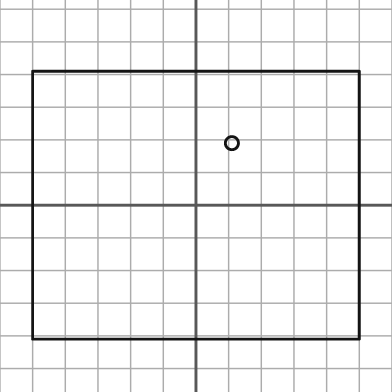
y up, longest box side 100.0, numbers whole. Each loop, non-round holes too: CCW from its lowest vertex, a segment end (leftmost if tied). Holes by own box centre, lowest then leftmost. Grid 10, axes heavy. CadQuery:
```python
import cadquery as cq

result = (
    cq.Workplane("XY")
    .moveTo(-50.0, -41.0)
    .lineTo(50.0, -41.0)
    .lineTo(50.0, 41.0)
    .lineTo(-50.0, 41.0)
    .close()
    .moveTo(11.0, 19.0)
    .circle(2.0)
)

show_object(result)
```